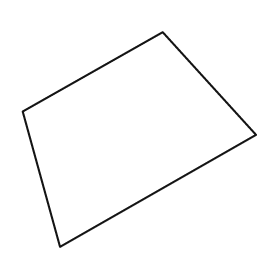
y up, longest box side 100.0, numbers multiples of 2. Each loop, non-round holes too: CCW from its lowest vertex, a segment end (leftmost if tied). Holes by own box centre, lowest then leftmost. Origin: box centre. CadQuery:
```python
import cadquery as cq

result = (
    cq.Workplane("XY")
    .moveTo(-34.0, -46.0)
    .lineTo(50.0, 2.0)
    .lineTo(10.0, 46.0)
    .lineTo(-50.0, 12.0)
    .close()
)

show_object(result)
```